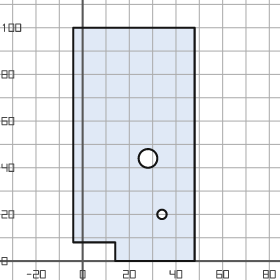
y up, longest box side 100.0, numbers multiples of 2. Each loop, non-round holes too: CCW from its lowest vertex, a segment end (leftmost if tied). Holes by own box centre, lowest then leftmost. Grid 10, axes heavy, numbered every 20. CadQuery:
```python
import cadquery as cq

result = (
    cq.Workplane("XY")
    .moveTo(14.0, 0.0)
    .lineTo(48.0, 0.0)
    .lineTo(48.0, 100.0)
    .lineTo(-4.0, 100.0)
    .lineTo(-4.0, 8.0)
    .lineTo(14.0, 8.0)
    .close()
    .moveTo(34.0, 20.0)
    .circle(2.0)
    .moveTo(28.0, 44.0)
    .circle(4.0)
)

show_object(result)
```